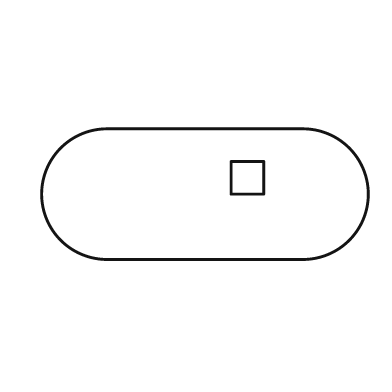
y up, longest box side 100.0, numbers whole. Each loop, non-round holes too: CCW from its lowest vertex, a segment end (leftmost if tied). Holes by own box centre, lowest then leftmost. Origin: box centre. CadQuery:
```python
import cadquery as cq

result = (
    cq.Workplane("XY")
    .moveTo(-30.0, -20.0)
    .lineTo(30.0, -20.0)
    .threePointArc((50.0, 0.0), (30.0, 20.0))
    .lineTo(-30.0, 20.0)
    .threePointArc((-50.0, 0.0), (-30.0, -20.0))
    .close()
    .moveTo(8.0, 0.0)
    .lineTo(18.0, 0.0)
    .lineTo(18.0, 10.0)
    .lineTo(8.0, 10.0)
    .close()
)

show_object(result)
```